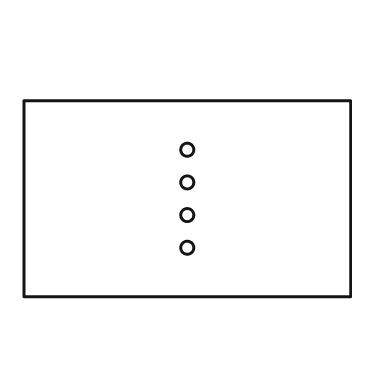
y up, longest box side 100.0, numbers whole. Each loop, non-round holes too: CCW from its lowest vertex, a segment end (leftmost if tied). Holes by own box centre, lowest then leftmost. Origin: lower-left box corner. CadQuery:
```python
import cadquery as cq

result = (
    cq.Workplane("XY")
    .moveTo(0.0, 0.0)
    .lineTo(100.0, 0.0)
    .lineTo(100.0, 60.0)
    .lineTo(0.0, 60.0)
    .close()
    .moveTo(50.0, 15.0)
    .circle(2.0)
    .moveTo(50.0, 25.0)
    .circle(2.0)
    .moveTo(50.0, 35.0)
    .circle(2.0)
    .moveTo(50.0, 45.0)
    .circle(2.0)
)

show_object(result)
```